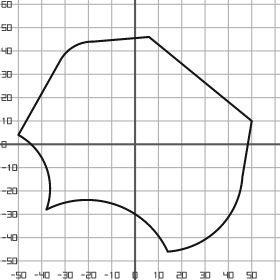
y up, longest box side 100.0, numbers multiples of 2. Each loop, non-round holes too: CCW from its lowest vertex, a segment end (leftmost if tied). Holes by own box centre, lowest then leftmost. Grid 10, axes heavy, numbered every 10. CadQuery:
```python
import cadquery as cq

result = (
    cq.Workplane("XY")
    .moveTo(14.0, -46.0)
    .threePointArc((36.0, -36.0), (46.0, -14.0))
    .lineTo(50.0, 10.0)
    .lineTo(6.0, 46.0)
    .lineTo(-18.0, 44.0)
    .threePointArc((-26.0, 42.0), (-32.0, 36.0))
    .lineTo(-50.0, 4.0)
    .threePointArc((-38.0, -10.0), (-38.0, -28.0))
    .threePointArc((-8.0, -26.0), (14.0, -46.0))
    .close()
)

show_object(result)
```